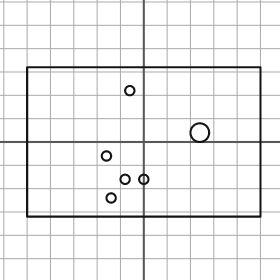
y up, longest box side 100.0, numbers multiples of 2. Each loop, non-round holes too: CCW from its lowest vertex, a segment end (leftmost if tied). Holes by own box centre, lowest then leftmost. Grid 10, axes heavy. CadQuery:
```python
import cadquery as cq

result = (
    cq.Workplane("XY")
    .moveTo(-50.0, -32.0)
    .lineTo(50.0, -32.0)
    .lineTo(50.0, 32.0)
    .lineTo(-50.0, 32.0)
    .close()
    .moveTo(-14.0, -24.0)
    .circle(2.0)
    .moveTo(-8.0, -16.0)
    .circle(2.0)
    .moveTo(0.0, -16.0)
    .circle(2.0)
    .moveTo(-16.0, -6.0)
    .circle(2.0)
    .moveTo(24.0, 4.0)
    .circle(4.0)
    .moveTo(-6.0, 22.0)
    .circle(2.0)
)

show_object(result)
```